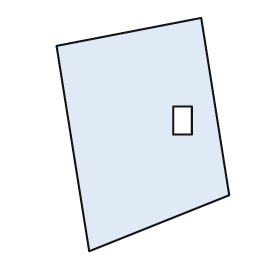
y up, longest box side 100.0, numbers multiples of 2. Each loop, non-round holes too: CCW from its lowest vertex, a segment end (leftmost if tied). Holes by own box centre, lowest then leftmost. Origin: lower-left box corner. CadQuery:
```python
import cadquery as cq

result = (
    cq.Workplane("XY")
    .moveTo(14.0, 0.0)
    .lineTo(74.0, 24.0)
    .lineTo(62.0, 100.0)
    .lineTo(0.0, 88.0)
    .close()
    .moveTo(50.0, 50.0)
    .lineTo(58.0, 50.0)
    .lineTo(58.0, 62.0)
    .lineTo(50.0, 62.0)
    .close()
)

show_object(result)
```